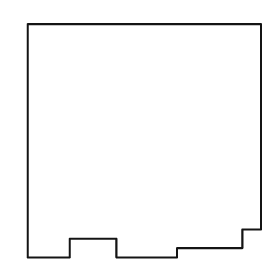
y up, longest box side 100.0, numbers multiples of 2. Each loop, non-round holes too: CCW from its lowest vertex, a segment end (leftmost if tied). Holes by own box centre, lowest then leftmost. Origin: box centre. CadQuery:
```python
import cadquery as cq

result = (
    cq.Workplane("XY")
    .moveTo(-50.0, -50.0)
    .lineTo(-32.0, -50.0)
    .lineTo(-32.0, -42.0)
    .lineTo(-12.0, -42.0)
    .lineTo(-12.0, -50.0)
    .lineTo(14.0, -50.0)
    .lineTo(14.0, -46.0)
    .lineTo(42.0, -46.0)
    .lineTo(42.0, -38.0)
    .lineTo(50.0, -38.0)
    .lineTo(50.0, 50.0)
    .lineTo(-50.0, 50.0)
    .close()
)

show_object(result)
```